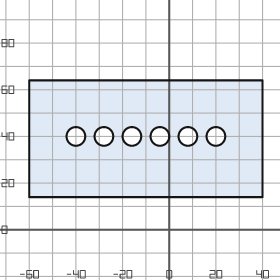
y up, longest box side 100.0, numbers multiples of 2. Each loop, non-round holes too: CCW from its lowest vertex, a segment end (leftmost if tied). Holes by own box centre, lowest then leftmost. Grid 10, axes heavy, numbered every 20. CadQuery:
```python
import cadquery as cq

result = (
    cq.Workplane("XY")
    .moveTo(-60.0, 14.0)
    .lineTo(40.0, 14.0)
    .lineTo(40.0, 64.0)
    .lineTo(-60.0, 64.0)
    .close()
    .moveTo(-40.0, 40.0)
    .circle(4.0)
    .moveTo(-28.0, 40.0)
    .circle(4.0)
    .moveTo(-16.0, 40.0)
    .circle(4.0)
    .moveTo(-4.0, 40.0)
    .circle(4.0)
    .moveTo(8.0, 40.0)
    .circle(4.0)
    .moveTo(20.0, 40.0)
    .circle(4.0)
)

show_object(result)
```